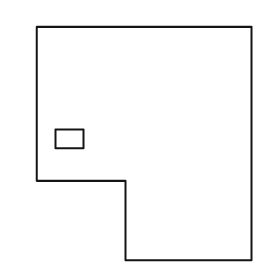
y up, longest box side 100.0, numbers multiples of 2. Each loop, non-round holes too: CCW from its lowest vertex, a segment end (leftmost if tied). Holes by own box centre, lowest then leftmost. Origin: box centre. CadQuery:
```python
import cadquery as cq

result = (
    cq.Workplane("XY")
    .moveTo(-8.0, -50.0)
    .lineTo(46.0, -50.0)
    .lineTo(46.0, 50.0)
    .lineTo(-46.0, 50.0)
    .lineTo(-46.0, -16.0)
    .lineTo(-8.0, -16.0)
    .close()
    .moveTo(-38.0, -2.0)
    .lineTo(-26.0, -2.0)
    .lineTo(-26.0, 6.0)
    .lineTo(-38.0, 6.0)
    .close()
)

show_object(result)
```